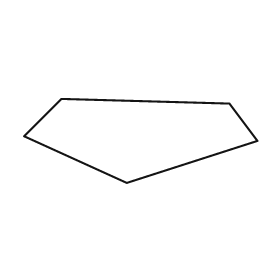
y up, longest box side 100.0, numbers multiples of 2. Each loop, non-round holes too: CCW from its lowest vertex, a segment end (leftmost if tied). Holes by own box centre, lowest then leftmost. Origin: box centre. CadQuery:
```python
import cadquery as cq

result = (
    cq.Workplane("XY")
    .moveTo(-6.0, -18.0)
    .lineTo(50.0, 0.0)
    .lineTo(38.0, 16.0)
    .lineTo(-34.0, 18.0)
    .lineTo(-50.0, 2.0)
    .close()
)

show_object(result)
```